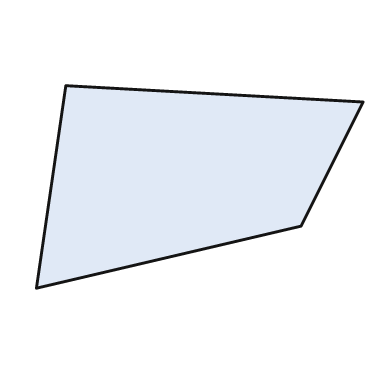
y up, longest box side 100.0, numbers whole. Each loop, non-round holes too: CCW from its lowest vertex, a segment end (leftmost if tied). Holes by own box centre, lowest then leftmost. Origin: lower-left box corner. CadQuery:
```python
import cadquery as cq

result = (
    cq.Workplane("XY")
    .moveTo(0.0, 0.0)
    .lineTo(81.0, 19.0)
    .lineTo(100.0, 57.0)
    .lineTo(9.0, 62.0)
    .close()
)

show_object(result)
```